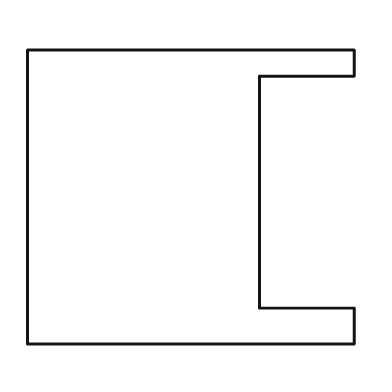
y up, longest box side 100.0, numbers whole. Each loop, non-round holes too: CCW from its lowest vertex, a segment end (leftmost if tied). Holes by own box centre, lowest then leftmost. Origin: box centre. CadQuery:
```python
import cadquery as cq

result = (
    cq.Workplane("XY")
    .moveTo(-50.0, -45.0)
    .lineTo(50.0, -45.0)
    .lineTo(50.0, -34.0)
    .lineTo(21.0, -34.0)
    .lineTo(21.0, 37.0)
    .lineTo(50.0, 37.0)
    .lineTo(50.0, 45.0)
    .lineTo(-50.0, 45.0)
    .close()
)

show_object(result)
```